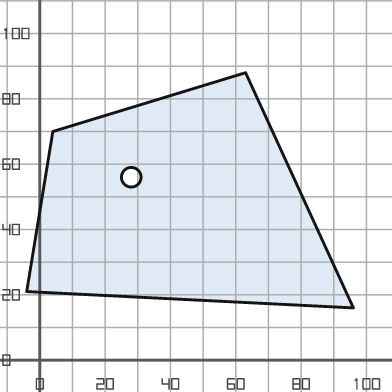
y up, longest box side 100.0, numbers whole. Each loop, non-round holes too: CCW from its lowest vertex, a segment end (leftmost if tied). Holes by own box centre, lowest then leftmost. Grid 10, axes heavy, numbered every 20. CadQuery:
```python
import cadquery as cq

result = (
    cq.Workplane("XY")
    .moveTo(96.0, 16.0)
    .lineTo(63.0, 88.0)
    .lineTo(4.0, 70.0)
    .lineTo(-4.0, 21.0)
    .close()
    .moveTo(28.0, 56.0)
    .circle(3.0)
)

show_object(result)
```